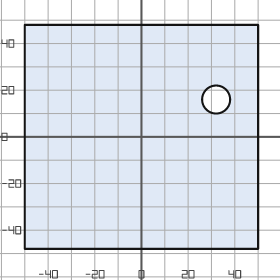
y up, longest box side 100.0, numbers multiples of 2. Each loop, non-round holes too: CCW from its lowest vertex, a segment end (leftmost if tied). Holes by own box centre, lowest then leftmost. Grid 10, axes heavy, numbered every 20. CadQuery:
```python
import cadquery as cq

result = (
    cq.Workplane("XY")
    .moveTo(-50.0, -48.0)
    .lineTo(50.0, -48.0)
    .lineTo(50.0, 48.0)
    .lineTo(-50.0, 48.0)
    .close()
    .moveTo(32.0, 16.0)
    .circle(6.0)
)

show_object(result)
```